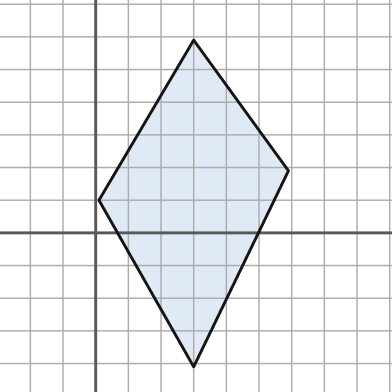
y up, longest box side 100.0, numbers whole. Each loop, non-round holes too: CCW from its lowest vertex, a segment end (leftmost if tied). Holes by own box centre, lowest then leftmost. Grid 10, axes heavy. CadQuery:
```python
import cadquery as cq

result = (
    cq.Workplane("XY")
    .moveTo(30.0, -41.0)
    .lineTo(59.0, 19.0)
    .lineTo(30.0, 59.0)
    .lineTo(1.0, 10.0)
    .close()
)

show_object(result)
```